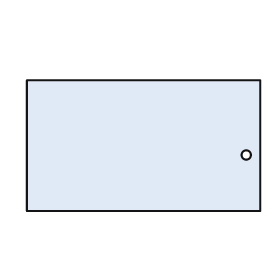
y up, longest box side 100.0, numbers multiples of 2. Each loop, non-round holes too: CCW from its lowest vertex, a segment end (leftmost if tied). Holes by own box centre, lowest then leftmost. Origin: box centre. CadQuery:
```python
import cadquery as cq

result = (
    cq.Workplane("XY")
    .moveTo(-50.0, -28.0)
    .lineTo(50.0, -28.0)
    .lineTo(50.0, 28.0)
    .lineTo(-50.0, 28.0)
    .close()
    .moveTo(44.0, -4.0)
    .circle(2.0)
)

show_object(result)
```